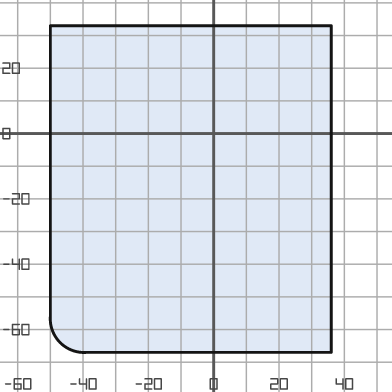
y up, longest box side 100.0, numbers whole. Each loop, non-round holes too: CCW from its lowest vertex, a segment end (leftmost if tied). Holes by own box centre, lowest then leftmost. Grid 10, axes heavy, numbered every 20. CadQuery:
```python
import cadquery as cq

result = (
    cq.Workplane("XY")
    .moveTo(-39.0, -67.0)
    .lineTo(36.0, -67.0)
    .lineTo(36.0, 33.0)
    .lineTo(-50.0, 33.0)
    .lineTo(-50.0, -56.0)
    .threePointArc((-47.0, -64.0), (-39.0, -67.0))
    .close()
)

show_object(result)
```